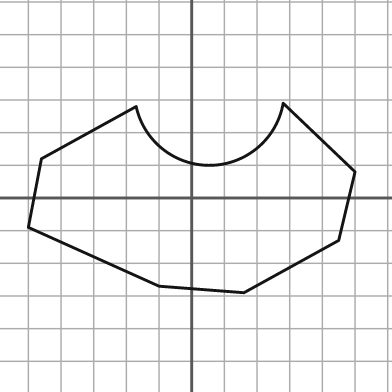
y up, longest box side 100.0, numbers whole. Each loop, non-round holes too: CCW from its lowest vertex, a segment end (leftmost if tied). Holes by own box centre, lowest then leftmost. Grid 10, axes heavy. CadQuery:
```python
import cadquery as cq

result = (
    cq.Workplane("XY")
    .moveTo(16.0, -29.0)
    .lineTo(45.0, -13.0)
    .lineTo(50.0, 8.0)
    .lineTo(28.0, 29.0)
    .threePointArc((6.0, 10.0), (-17.0, 28.0))
    .lineTo(-46.0, 12.0)
    .lineTo(-50.0, -9.0)
    .lineTo(-10.0, -27.0)
    .close()
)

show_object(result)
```